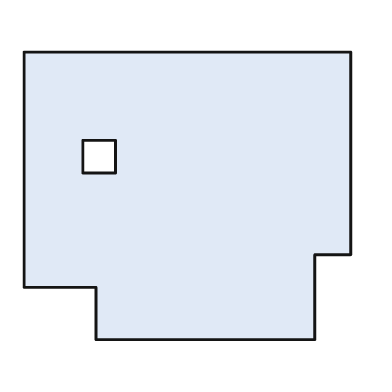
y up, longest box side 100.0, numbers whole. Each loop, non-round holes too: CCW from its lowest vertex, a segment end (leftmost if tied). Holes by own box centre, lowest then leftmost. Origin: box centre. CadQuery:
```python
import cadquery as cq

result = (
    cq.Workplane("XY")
    .moveTo(-28.0, -44.0)
    .lineTo(39.0, -44.0)
    .lineTo(39.0, -18.0)
    .lineTo(50.0, -18.0)
    .lineTo(50.0, 44.0)
    .lineTo(-50.0, 44.0)
    .lineTo(-50.0, -28.0)
    .lineTo(-28.0, -28.0)
    .close()
    .moveTo(-32.0, 7.0)
    .lineTo(-22.0, 7.0)
    .lineTo(-22.0, 17.0)
    .lineTo(-32.0, 17.0)
    .close()
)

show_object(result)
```